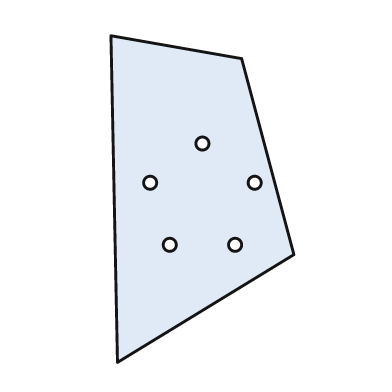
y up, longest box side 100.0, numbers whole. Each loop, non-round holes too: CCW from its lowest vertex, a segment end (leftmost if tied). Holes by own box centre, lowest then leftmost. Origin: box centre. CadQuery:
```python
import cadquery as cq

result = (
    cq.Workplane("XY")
    .moveTo(-26.0, -50.0)
    .lineTo(28.0, -17.0)
    .lineTo(12.0, 43.0)
    .lineTo(-28.0, 50.0)
    .close()
    .moveTo(-10.0, -14.0)
    .circle(2.0)
    .moveTo(10.0, -14.0)
    .circle(2.0)
    .moveTo(-16.0, 5.0)
    .circle(2.0)
    .moveTo(16.0, 5.0)
    .circle(2.0)
    .moveTo(0.0, 17.0)
    .circle(2.0)
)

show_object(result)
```